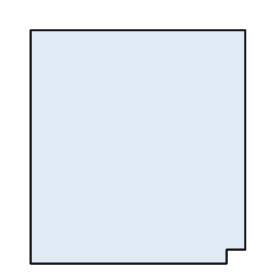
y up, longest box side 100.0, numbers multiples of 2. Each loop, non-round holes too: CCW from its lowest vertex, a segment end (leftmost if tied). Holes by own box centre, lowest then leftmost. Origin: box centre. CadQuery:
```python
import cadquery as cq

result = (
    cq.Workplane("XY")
    .moveTo(-46.0, -50.0)
    .lineTo(38.0, -50.0)
    .lineTo(38.0, -44.0)
    .lineTo(46.0, -44.0)
    .lineTo(46.0, 50.0)
    .lineTo(-46.0, 50.0)
    .close()
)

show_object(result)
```